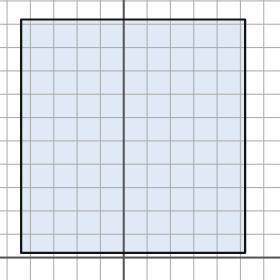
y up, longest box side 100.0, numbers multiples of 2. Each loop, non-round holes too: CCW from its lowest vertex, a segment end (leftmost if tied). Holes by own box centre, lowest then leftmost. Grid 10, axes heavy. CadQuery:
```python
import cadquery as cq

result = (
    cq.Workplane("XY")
    .moveTo(-44.0, 2.0)
    .lineTo(52.0, 2.0)
    .lineTo(52.0, 102.0)
    .lineTo(-44.0, 102.0)
    .close()
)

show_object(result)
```